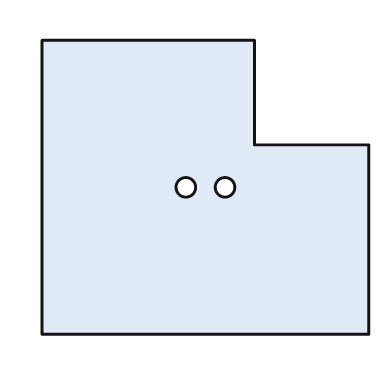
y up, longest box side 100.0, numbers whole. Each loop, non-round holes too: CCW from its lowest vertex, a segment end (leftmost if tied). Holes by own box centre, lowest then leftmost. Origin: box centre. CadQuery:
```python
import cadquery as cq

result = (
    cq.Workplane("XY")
    .moveTo(-50.0, -45.0)
    .lineTo(50.0, -45.0)
    .lineTo(50.0, 13.0)
    .lineTo(15.0, 13.0)
    .lineTo(15.0, 45.0)
    .lineTo(-50.0, 45.0)
    .close()
    .moveTo(-6.0, 0.0)
    .circle(3.0)
    .moveTo(6.0, 0.0)
    .circle(3.0)
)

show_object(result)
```